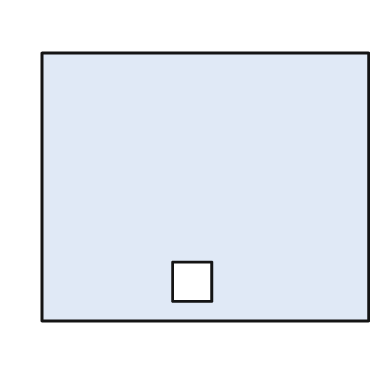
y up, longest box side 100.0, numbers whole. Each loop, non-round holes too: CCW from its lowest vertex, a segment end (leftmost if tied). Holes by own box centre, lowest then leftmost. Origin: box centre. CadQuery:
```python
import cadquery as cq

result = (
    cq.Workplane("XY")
    .moveTo(-50.0, -41.0)
    .lineTo(50.0, -41.0)
    .lineTo(50.0, 41.0)
    .lineTo(-50.0, 41.0)
    .close()
    .moveTo(-10.0, -35.0)
    .lineTo(2.0, -35.0)
    .lineTo(2.0, -23.0)
    .lineTo(-10.0, -23.0)
    .close()
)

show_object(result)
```